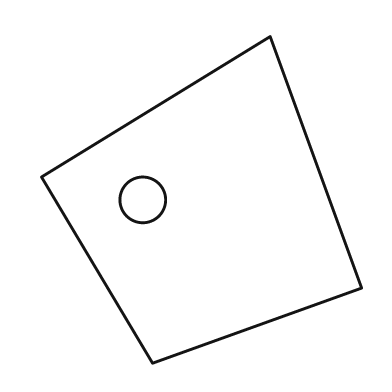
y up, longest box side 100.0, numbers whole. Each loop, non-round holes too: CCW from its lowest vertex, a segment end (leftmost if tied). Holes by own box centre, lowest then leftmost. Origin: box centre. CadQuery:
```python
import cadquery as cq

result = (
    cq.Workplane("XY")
    .moveTo(-15.0, -50.0)
    .lineTo(49.0, -27.0)
    .lineTo(21.0, 50.0)
    .lineTo(-49.0, 7.0)
    .close()
    .moveTo(-18.0, 0.0)
    .circle(7.0)
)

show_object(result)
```